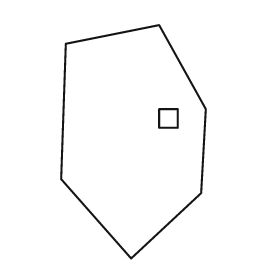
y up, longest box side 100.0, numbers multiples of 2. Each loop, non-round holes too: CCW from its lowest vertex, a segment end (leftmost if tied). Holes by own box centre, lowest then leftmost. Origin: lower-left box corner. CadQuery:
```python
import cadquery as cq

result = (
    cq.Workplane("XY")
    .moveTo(30.0, 0.0)
    .lineTo(60.0, 28.0)
    .lineTo(62.0, 64.0)
    .lineTo(42.0, 100.0)
    .lineTo(2.0, 92.0)
    .lineTo(0.0, 34.0)
    .close()
    .moveTo(42.0, 56.0)
    .lineTo(50.0, 56.0)
    .lineTo(50.0, 64.0)
    .lineTo(42.0, 64.0)
    .close()
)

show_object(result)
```